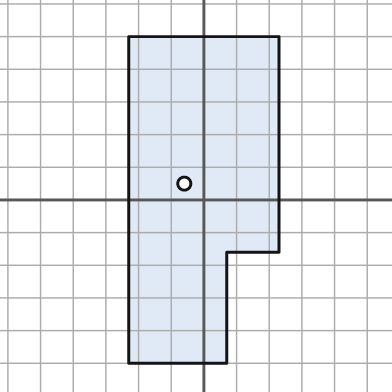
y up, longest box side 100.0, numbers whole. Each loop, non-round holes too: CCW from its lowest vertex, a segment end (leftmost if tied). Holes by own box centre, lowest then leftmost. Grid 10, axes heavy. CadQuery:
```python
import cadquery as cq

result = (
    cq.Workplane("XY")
    .moveTo(-23.0, -50.0)
    .lineTo(7.0, -50.0)
    .lineTo(7.0, -16.0)
    .lineTo(23.0, -16.0)
    .lineTo(23.0, 50.0)
    .lineTo(-23.0, 50.0)
    .close()
    .moveTo(-6.0, 5.0)
    .circle(2.0)
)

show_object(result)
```